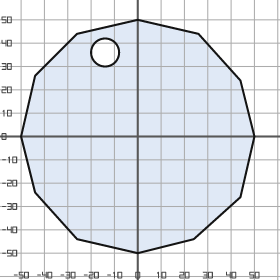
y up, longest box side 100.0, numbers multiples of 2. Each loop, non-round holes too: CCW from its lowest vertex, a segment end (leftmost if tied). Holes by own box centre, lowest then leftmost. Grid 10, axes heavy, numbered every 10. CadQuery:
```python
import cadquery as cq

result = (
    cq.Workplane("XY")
    .moveTo(0.0, -50.0)
    .lineTo(24.0, -44.0)
    .lineTo(44.0, -26.0)
    .lineTo(50.0, 0.0)
    .lineTo(44.0, 24.0)
    .lineTo(26.0, 44.0)
    .lineTo(0.0, 50.0)
    .lineTo(-26.0, 44.0)
    .lineTo(-44.0, 26.0)
    .lineTo(-50.0, 0.0)
    .lineTo(-44.0, -24.0)
    .lineTo(-26.0, -44.0)
    .close()
    .moveTo(-14.0, 36.0)
    .circle(6.0)
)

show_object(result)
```